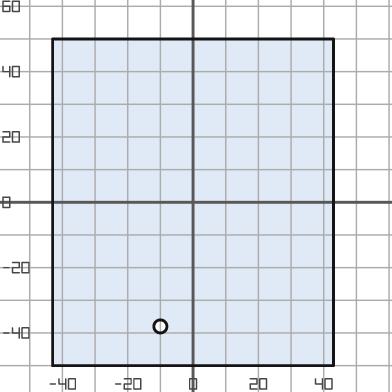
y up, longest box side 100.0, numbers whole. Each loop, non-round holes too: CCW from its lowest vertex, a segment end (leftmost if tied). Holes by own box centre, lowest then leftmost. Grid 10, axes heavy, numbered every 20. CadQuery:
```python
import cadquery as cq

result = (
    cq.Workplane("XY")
    .moveTo(-43.0, -50.0)
    .lineTo(43.0, -50.0)
    .lineTo(43.0, 50.0)
    .lineTo(-43.0, 50.0)
    .close()
    .moveTo(-10.0, -38.0)
    .circle(2.0)
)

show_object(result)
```